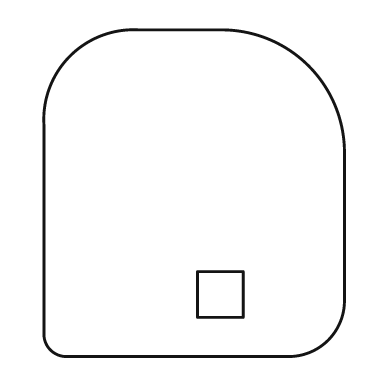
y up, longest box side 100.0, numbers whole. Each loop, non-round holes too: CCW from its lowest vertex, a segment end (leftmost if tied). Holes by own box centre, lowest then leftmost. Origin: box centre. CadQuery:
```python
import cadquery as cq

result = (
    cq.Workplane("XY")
    .moveTo(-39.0, -50.0)
    .lineTo(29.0, -50.0)
    .threePointArc((41.0, -45.0), (46.0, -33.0))
    .lineTo(46.0, 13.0)
    .threePointArc((35.0, 39.0), (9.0, 50.0))
    .lineTo(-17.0, 50.0)
    .threePointArc((-38.0, 42.0), (-46.0, 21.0))
    .lineTo(-46.0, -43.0)
    .threePointArc((-44.0, -48.0), (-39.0, -50.0))
    .close()
    .moveTo(1.0, -38.0)
    .lineTo(15.0, -38.0)
    .lineTo(15.0, -24.0)
    .lineTo(1.0, -24.0)
    .close()
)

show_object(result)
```